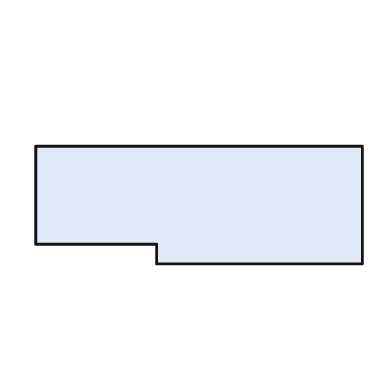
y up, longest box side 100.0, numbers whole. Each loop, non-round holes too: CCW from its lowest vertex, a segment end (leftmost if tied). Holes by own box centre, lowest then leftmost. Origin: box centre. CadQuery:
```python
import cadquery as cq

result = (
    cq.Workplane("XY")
    .moveTo(-13.0, -18.0)
    .lineTo(50.0, -18.0)
    .lineTo(50.0, 18.0)
    .lineTo(-50.0, 18.0)
    .lineTo(-50.0, -12.0)
    .lineTo(-13.0, -12.0)
    .close()
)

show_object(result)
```